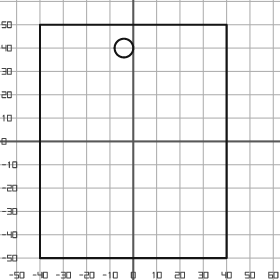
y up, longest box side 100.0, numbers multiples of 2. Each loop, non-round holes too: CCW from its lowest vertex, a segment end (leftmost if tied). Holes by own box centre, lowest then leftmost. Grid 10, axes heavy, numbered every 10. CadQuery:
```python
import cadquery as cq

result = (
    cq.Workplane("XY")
    .moveTo(-40.0, -50.0)
    .lineTo(40.0, -50.0)
    .lineTo(40.0, 50.0)
    .lineTo(-40.0, 50.0)
    .close()
    .moveTo(-4.0, 40.0)
    .circle(4.0)
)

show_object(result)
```